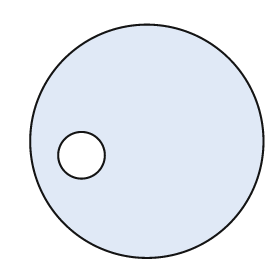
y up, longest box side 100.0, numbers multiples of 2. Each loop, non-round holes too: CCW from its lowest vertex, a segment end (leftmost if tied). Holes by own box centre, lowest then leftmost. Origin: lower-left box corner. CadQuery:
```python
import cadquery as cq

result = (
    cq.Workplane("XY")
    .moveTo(50.0, 50.0)
    .circle(50.0)
    .moveTo(22.0, 44.0)
    .circle(10.0)
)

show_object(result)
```